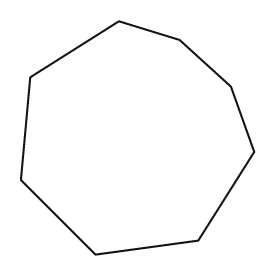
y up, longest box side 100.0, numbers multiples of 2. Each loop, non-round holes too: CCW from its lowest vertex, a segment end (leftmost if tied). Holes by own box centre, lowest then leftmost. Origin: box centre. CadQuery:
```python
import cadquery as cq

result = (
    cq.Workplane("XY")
    .moveTo(-18.0, -50.0)
    .lineTo(26.0, -44.0)
    .lineTo(50.0, -6.0)
    .lineTo(40.0, 22.0)
    .lineTo(18.0, 42.0)
    .lineTo(-8.0, 50.0)
    .lineTo(-46.0, 26.0)
    .lineTo(-50.0, -18.0)
    .close()
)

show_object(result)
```